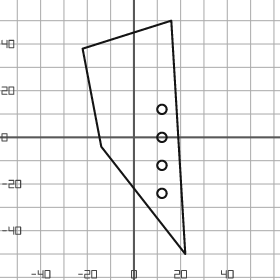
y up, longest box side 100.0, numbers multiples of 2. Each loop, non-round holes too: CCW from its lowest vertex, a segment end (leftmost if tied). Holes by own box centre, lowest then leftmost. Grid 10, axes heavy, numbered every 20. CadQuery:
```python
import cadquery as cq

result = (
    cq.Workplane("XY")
    .moveTo(22.0, -50.0)
    .lineTo(16.0, 50.0)
    .lineTo(-22.0, 38.0)
    .lineTo(-14.0, -4.0)
    .close()
    .moveTo(12.0, -24.0)
    .circle(2.0)
    .moveTo(12.0, -12.0)
    .circle(2.0)
    .moveTo(12.0, 0.0)
    .circle(2.0)
    .moveTo(12.0, 12.0)
    .circle(2.0)
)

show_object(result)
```